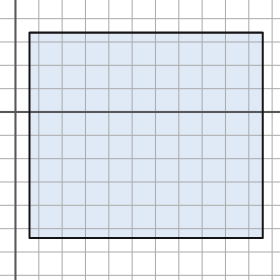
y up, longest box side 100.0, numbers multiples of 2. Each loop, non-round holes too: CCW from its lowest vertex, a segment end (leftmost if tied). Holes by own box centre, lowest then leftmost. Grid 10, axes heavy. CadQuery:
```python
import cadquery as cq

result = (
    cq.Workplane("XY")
    .moveTo(6.0, -54.0)
    .lineTo(106.0, -54.0)
    .lineTo(106.0, 34.0)
    .lineTo(6.0, 34.0)
    .close()
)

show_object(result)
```